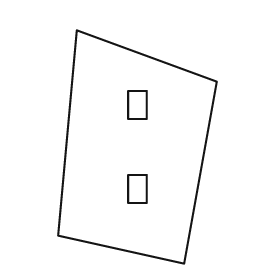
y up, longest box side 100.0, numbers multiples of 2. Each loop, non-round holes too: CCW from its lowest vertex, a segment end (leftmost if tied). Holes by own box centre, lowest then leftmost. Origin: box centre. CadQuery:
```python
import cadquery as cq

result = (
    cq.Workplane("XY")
    .moveTo(20.0, -50.0)
    .lineTo(34.0, 28.0)
    .lineTo(-26.0, 50.0)
    .lineTo(-34.0, -38.0)
    .close()
    .moveTo(-4.0, -24.0)
    .lineTo(4.0, -24.0)
    .lineTo(4.0, -12.0)
    .lineTo(-4.0, -12.0)
    .close()
    .moveTo(-4.0, 12.0)
    .lineTo(4.0, 12.0)
    .lineTo(4.0, 24.0)
    .lineTo(-4.0, 24.0)
    .close()
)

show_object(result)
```